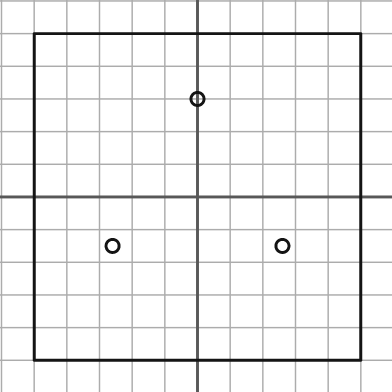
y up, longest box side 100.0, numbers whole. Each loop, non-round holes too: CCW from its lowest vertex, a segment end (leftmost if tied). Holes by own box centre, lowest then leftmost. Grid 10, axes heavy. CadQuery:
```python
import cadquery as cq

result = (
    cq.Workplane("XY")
    .moveTo(-50.0, -50.0)
    .lineTo(50.0, -50.0)
    .lineTo(50.0, 50.0)
    .lineTo(-50.0, 50.0)
    .close()
    .moveTo(-26.0, -15.0)
    .circle(2.0)
    .moveTo(26.0, -15.0)
    .circle(2.0)
    .moveTo(0.0, 30.0)
    .circle(2.0)
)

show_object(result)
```